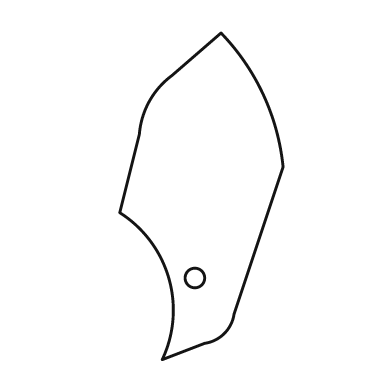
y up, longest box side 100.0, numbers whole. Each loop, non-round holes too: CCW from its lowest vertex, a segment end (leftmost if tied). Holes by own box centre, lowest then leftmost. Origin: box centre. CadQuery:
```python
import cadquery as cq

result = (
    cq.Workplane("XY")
    .moveTo(-12.0, -50.0)
    .lineTo(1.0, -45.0)
    .threePointArc((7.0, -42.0), (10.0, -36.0))
    .lineTo(25.0, 9.0)
    .threePointArc((19.0, 31.0), (6.0, 50.0))
    .lineTo(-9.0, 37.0)
    .threePointArc((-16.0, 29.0), (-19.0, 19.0))
    .lineTo(-25.0, -5.0)
    .threePointArc((-10.0, -25.0), (-12.0, -50.0))
    .close()
    .moveTo(-2.0, -25.0)
    .circle(3.0)
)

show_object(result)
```